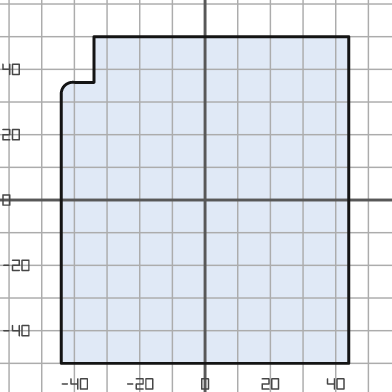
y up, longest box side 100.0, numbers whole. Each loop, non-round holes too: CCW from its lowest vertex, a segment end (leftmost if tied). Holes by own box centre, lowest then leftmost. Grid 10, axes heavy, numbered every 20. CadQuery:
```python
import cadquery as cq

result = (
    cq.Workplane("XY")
    .moveTo(-44.0, -50.0)
    .lineTo(44.0, -50.0)
    .lineTo(44.0, 50.0)
    .lineTo(-34.0, 50.0)
    .lineTo(-34.0, 36.0)
    .lineTo(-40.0, 36.0)
    .threePointArc((-43.0, 35.0), (-44.0, 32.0))
    .close()
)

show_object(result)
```